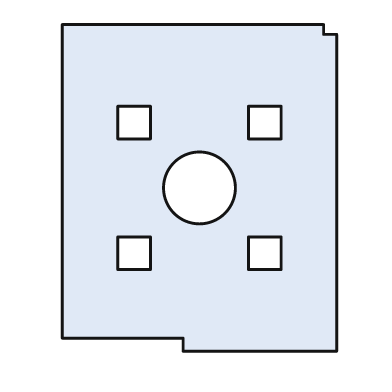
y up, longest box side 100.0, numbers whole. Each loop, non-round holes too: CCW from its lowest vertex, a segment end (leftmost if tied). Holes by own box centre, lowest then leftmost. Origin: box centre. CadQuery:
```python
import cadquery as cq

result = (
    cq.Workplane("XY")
    .moveTo(-5.0, -50.0)
    .lineTo(42.0, -50.0)
    .lineTo(42.0, 47.0)
    .lineTo(38.0, 47.0)
    .lineTo(38.0, 50.0)
    .lineTo(-42.0, 50.0)
    .lineTo(-42.0, -46.0)
    .lineTo(-5.0, -46.0)
    .close()
    .moveTo(-25.0, -25.0)
    .lineTo(-15.0, -25.0)
    .lineTo(-15.0, -15.0)
    .lineTo(-25.0, -15.0)
    .close()
    .moveTo(15.0, -25.0)
    .lineTo(25.0, -25.0)
    .lineTo(25.0, -15.0)
    .lineTo(15.0, -15.0)
    .close()
    .moveTo(0.0, 0.0)
    .circle(11.0)
    .moveTo(-25.0, 15.0)
    .lineTo(-15.0, 15.0)
    .lineTo(-15.0, 25.0)
    .lineTo(-25.0, 25.0)
    .close()
    .moveTo(15.0, 15.0)
    .lineTo(25.0, 15.0)
    .lineTo(25.0, 25.0)
    .lineTo(15.0, 25.0)
    .close()
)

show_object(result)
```